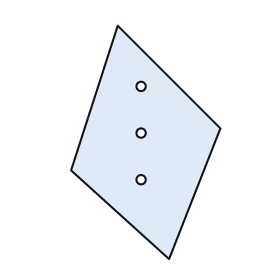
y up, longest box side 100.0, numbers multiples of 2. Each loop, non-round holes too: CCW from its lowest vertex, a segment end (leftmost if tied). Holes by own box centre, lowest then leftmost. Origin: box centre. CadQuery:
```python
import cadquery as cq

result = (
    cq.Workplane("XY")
    .moveTo(10.0, -50.0)
    .lineTo(32.0, 6.0)
    .lineTo(-12.0, 50.0)
    .lineTo(-32.0, -12.0)
    .close()
    .moveTo(-2.0, -16.0)
    .circle(2.0)
    .moveTo(-2.0, 4.0)
    .circle(2.0)
    .moveTo(-2.0, 24.0)
    .circle(2.0)
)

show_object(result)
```